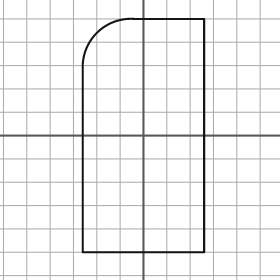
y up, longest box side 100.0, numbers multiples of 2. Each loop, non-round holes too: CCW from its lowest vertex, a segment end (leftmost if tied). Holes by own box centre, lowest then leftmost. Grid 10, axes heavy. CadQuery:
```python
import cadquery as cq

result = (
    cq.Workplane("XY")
    .moveTo(-26.0, -50.0)
    .lineTo(26.0, -50.0)
    .lineTo(26.0, 50.0)
    .lineTo(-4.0, 50.0)
    .threePointArc((-20.0, 44.0), (-26.0, 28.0))
    .close()
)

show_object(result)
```